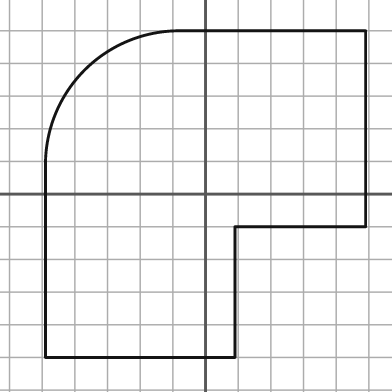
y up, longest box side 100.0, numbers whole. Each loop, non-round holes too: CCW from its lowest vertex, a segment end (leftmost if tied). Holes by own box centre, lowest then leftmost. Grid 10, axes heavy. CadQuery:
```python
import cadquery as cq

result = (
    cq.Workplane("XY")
    .moveTo(-49.0, -50.0)
    .lineTo(9.0, -50.0)
    .lineTo(9.0, -10.0)
    .lineTo(49.0, -10.0)
    .lineTo(49.0, 50.0)
    .lineTo(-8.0, 50.0)
    .threePointArc((-37.0, 38.0), (-49.0, 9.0))
    .close()
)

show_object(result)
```